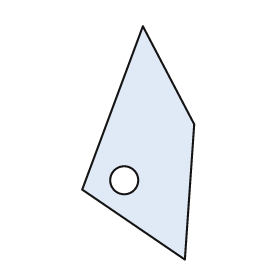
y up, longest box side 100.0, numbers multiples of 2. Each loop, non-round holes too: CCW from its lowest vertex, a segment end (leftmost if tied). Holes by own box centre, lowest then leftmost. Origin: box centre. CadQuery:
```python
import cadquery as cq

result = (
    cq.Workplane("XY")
    .moveTo(20.0, -50.0)
    .lineTo(24.0, 8.0)
    .lineTo(2.0, 50.0)
    .lineTo(-24.0, -20.0)
    .close()
    .moveTo(-6.0, -16.0)
    .circle(6.0)
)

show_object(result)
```